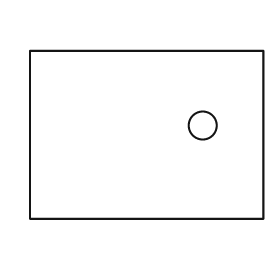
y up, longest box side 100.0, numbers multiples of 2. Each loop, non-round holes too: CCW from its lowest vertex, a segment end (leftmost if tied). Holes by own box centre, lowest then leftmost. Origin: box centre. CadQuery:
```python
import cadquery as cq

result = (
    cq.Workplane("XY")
    .moveTo(-50.0, -36.0)
    .lineTo(50.0, -36.0)
    .lineTo(50.0, 36.0)
    .lineTo(-50.0, 36.0)
    .close()
    .moveTo(24.0, 4.0)
    .circle(6.0)
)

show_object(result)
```